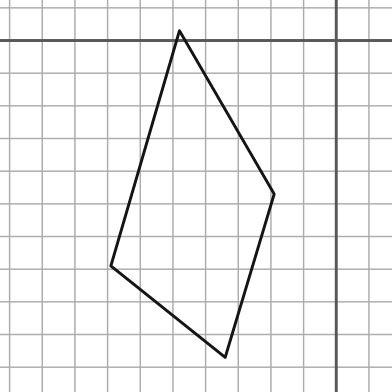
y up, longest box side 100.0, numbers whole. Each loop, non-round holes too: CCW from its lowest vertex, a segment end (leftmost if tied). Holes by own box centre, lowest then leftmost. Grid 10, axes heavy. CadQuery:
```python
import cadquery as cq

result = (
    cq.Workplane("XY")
    .moveTo(-34.0, -97.0)
    .lineTo(-19.0, -47.0)
    .lineTo(-48.0, 3.0)
    .lineTo(-69.0, -69.0)
    .close()
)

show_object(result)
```